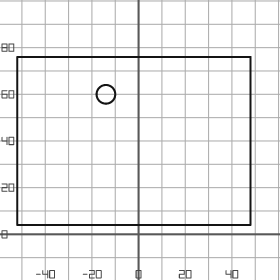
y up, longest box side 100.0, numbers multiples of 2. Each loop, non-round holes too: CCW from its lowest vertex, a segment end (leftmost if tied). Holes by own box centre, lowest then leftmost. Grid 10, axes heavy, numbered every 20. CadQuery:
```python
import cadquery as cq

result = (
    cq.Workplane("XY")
    .moveTo(-52.0, 4.0)
    .lineTo(48.0, 4.0)
    .lineTo(48.0, 76.0)
    .lineTo(-52.0, 76.0)
    .close()
    .moveTo(-14.0, 60.0)
    .circle(4.0)
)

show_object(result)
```